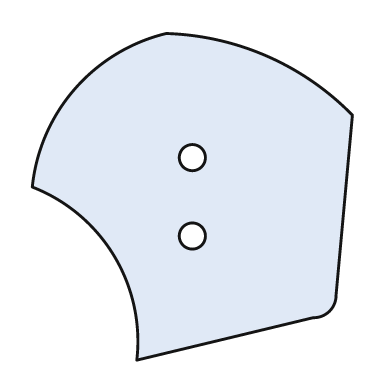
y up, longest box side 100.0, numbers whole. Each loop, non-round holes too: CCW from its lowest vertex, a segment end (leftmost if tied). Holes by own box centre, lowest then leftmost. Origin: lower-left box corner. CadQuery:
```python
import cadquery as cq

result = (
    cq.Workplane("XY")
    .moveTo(32.0, 0.0)
    .lineTo(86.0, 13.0)
    .threePointArc((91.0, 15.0), (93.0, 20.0))
    .lineTo(98.0, 75.0)
    .threePointArc((72.0, 93.0), (41.0, 100.0))
    .threePointArc((13.0, 83.0), (0.0, 53.0))
    .threePointArc((25.0, 32.0), (32.0, 0.0))
    .close()
    .moveTo(49.0, 38.0)
    .circle(4.0)
    .moveTo(49.0, 62.0)
    .circle(4.0)
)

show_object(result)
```